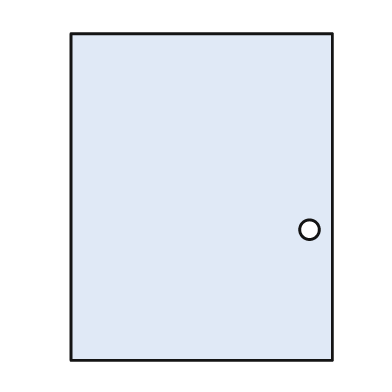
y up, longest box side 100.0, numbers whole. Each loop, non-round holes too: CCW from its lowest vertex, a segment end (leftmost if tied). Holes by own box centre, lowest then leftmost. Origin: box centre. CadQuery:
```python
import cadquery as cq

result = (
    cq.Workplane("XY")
    .moveTo(-40.0, -50.0)
    .lineTo(40.0, -50.0)
    .lineTo(40.0, 50.0)
    .lineTo(-40.0, 50.0)
    .close()
    .moveTo(33.0, -10.0)
    .circle(3.0)
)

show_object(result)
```